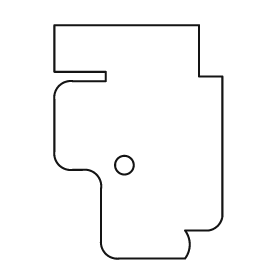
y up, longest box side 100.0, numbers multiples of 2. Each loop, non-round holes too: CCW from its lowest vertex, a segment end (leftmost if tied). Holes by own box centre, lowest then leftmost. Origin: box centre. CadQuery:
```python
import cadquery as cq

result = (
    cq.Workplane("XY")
    .moveTo(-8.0, -50.0)
    .lineTo(20.0, -50.0)
    .threePointArc((22.0, -44.0), (20.0, -38.0))
    .lineTo(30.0, -38.0)
    .threePointArc((34.0, -36.0), (36.0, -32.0))
    .lineTo(36.0, 28.0)
    .lineTo(26.0, 28.0)
    .lineTo(26.0, 50.0)
    .lineTo(-36.0, 50.0)
    .lineTo(-36.0, 30.0)
    .lineTo(-14.0, 30.0)
    .lineTo(-14.0, 26.0)
    .lineTo(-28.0, 26.0)
    .threePointArc((-34.0, 24.0), (-36.0, 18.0))
    .lineTo(-36.0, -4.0)
    .threePointArc((-34.0, -10.0), (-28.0, -12.0))
    .lineTo(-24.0, -12.0)
    .threePointArc((-18.0, -14.0), (-16.0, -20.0))
    .lineTo(-16.0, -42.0)
    .threePointArc((-14.0, -48.0), (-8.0, -50.0))
    .close()
    .moveTo(-6.0, -10.0)
    .circle(4.0)
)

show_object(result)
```